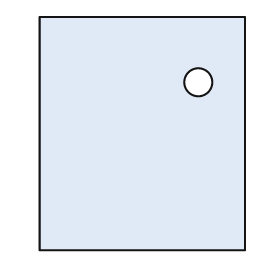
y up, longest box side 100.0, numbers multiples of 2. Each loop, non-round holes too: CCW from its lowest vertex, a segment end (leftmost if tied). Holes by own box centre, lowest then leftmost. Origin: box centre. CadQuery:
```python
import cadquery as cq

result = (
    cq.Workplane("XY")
    .moveTo(-44.0, -50.0)
    .lineTo(44.0, -50.0)
    .lineTo(44.0, 50.0)
    .lineTo(-44.0, 50.0)
    .close()
    .moveTo(24.0, 22.0)
    .circle(6.0)
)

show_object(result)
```